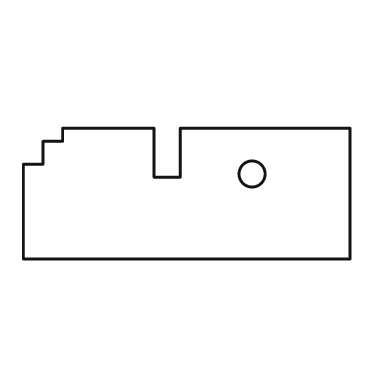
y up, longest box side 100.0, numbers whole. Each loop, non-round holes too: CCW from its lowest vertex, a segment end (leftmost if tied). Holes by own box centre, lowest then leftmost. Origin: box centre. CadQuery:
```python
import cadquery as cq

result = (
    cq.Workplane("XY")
    .moveTo(-50.0, -20.0)
    .lineTo(50.0, -20.0)
    .lineTo(50.0, 20.0)
    .lineTo(-2.0, 20.0)
    .lineTo(-2.0, 5.0)
    .lineTo(-10.0, 5.0)
    .lineTo(-10.0, 20.0)
    .lineTo(-38.0, 20.0)
    .lineTo(-38.0, 16.0)
    .lineTo(-44.0, 16.0)
    .lineTo(-44.0, 9.0)
    .lineTo(-50.0, 9.0)
    .close()
    .moveTo(20.0, 6.0)
    .circle(4.0)
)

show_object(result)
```